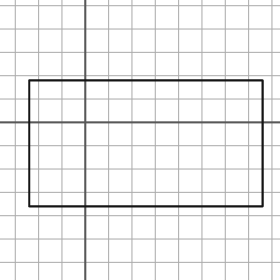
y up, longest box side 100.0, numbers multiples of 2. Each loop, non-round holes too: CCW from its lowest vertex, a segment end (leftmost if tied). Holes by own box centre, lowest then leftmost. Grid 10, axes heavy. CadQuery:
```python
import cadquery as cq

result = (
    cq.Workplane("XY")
    .moveTo(-24.0, -36.0)
    .lineTo(76.0, -36.0)
    .lineTo(76.0, 18.0)
    .lineTo(-24.0, 18.0)
    .close()
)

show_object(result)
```